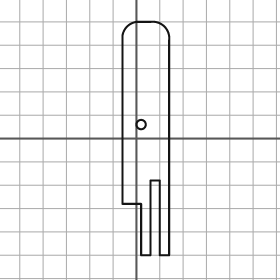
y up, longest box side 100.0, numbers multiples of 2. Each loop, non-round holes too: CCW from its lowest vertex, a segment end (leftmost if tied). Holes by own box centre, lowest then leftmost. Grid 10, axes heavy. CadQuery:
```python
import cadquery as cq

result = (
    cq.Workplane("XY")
    .moveTo(2.0, -50.0)
    .lineTo(6.0, -50.0)
    .lineTo(6.0, -18.0)
    .lineTo(10.0, -18.0)
    .lineTo(10.0, -50.0)
    .lineTo(14.0, -50.0)
    .lineTo(14.0, 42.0)
    .threePointArc((12.0, 48.0), (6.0, 50.0))
    .lineTo(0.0, 50.0)
    .threePointArc((-4.0, 48.0), (-6.0, 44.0))
    .lineTo(-6.0, -28.0)
    .lineTo(2.0, -28.0)
    .close()
    .moveTo(2.0, 6.0)
    .circle(2.0)
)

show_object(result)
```